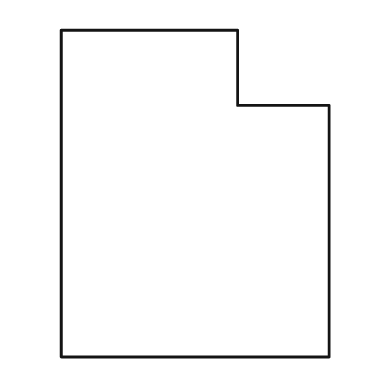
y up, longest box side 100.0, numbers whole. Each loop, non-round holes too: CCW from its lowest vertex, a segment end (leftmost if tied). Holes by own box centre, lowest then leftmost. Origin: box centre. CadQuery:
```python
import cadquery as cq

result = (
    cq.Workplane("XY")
    .moveTo(-41.0, -50.0)
    .lineTo(41.0, -50.0)
    .lineTo(41.0, 27.0)
    .lineTo(13.0, 27.0)
    .lineTo(13.0, 50.0)
    .lineTo(-41.0, 50.0)
    .close()
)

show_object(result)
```